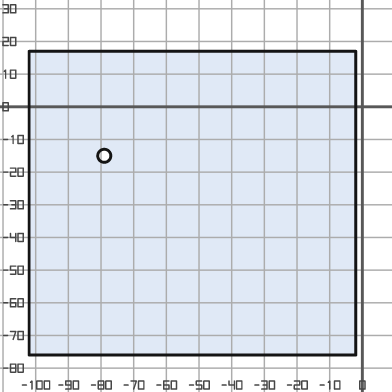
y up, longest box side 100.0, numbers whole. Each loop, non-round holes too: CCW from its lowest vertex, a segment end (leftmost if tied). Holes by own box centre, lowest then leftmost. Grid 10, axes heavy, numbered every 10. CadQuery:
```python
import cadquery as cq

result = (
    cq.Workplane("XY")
    .moveTo(-102.0, -76.0)
    .lineTo(-2.0, -76.0)
    .lineTo(-2.0, 17.0)
    .lineTo(-102.0, 17.0)
    .close()
    .moveTo(-79.0, -15.0)
    .circle(2.0)
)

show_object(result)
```